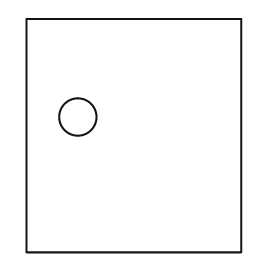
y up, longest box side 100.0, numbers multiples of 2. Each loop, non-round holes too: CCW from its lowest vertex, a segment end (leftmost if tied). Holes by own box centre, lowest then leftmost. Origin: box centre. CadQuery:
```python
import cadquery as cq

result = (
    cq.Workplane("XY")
    .moveTo(-46.0, -50.0)
    .lineTo(46.0, -50.0)
    .lineTo(46.0, 50.0)
    .lineTo(-46.0, 50.0)
    .close()
    .moveTo(-24.0, 8.0)
    .circle(8.0)
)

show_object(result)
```